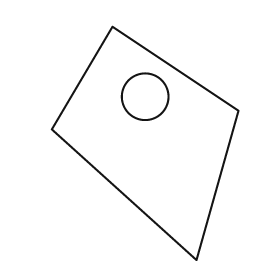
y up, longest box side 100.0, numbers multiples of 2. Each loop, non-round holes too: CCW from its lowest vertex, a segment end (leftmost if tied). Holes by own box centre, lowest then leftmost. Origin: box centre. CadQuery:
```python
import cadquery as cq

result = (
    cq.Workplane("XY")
    .moveTo(22.0, -50.0)
    .lineTo(40.0, 14.0)
    .lineTo(-14.0, 50.0)
    .lineTo(-40.0, 6.0)
    .close()
    .moveTo(0.0, 20.0)
    .circle(10.0)
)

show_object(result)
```